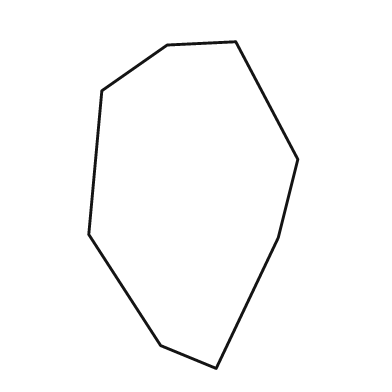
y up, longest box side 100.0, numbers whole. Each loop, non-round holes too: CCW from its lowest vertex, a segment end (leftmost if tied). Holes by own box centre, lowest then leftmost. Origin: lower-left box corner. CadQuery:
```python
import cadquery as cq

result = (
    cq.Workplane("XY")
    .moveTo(39.0, 0.0)
    .lineTo(58.0, 40.0)
    .lineTo(64.0, 64.0)
    .lineTo(45.0, 100.0)
    .lineTo(24.0, 99.0)
    .lineTo(4.0, 85.0)
    .lineTo(0.0, 41.0)
    .lineTo(22.0, 7.0)
    .close()
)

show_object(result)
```